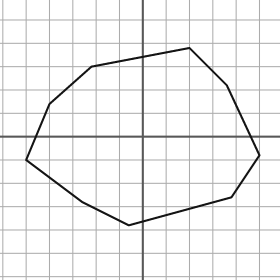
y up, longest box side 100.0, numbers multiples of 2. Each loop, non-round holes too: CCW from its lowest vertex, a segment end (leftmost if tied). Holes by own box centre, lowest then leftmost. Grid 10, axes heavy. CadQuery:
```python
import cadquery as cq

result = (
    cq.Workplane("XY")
    .moveTo(-6.0, -38.0)
    .lineTo(38.0, -26.0)
    .lineTo(50.0, -8.0)
    .lineTo(36.0, 22.0)
    .lineTo(20.0, 38.0)
    .lineTo(-22.0, 30.0)
    .lineTo(-40.0, 14.0)
    .lineTo(-50.0, -10.0)
    .lineTo(-26.0, -28.0)
    .close()
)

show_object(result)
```